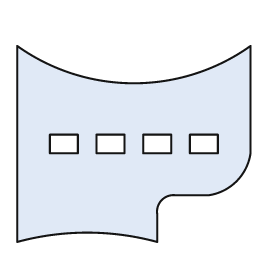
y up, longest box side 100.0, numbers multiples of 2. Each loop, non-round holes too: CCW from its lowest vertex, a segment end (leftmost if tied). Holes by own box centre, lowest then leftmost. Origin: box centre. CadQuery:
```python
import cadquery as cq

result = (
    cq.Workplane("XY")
    .moveTo(-50.0, -42.0)
    .threePointArc((-20.0, -38.0), (10.0, -42.0))
    .lineTo(10.0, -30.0)
    .threePointArc((12.0, -24.0), (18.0, -22.0))
    .lineTo(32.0, -22.0)
    .threePointArc((44.0, -16.0), (50.0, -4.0))
    .lineTo(50.0, 42.0)
    .threePointArc((0.0, 26.0), (-50.0, 42.0))
    .close()
    .moveTo(-36.0, -4.0)
    .lineTo(-24.0, -4.0)
    .lineTo(-24.0, 4.0)
    .lineTo(-36.0, 4.0)
    .close()
    .moveTo(-16.0, -4.0)
    .lineTo(-4.0, -4.0)
    .lineTo(-4.0, 4.0)
    .lineTo(-16.0, 4.0)
    .close()
    .moveTo(4.0, -4.0)
    .lineTo(16.0, -4.0)
    .lineTo(16.0, 4.0)
    .lineTo(4.0, 4.0)
    .close()
    .moveTo(24.0, -4.0)
    .lineTo(36.0, -4.0)
    .lineTo(36.0, 4.0)
    .lineTo(24.0, 4.0)
    .close()
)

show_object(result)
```